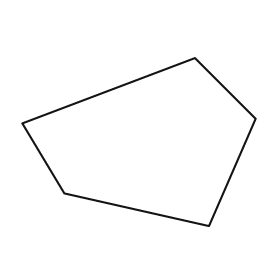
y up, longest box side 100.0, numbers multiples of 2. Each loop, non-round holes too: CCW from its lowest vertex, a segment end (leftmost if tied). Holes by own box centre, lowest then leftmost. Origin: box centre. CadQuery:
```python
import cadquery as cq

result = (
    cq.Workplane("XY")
    .moveTo(30.0, -36.0)
    .lineTo(50.0, 10.0)
    .lineTo(24.0, 36.0)
    .lineTo(-50.0, 8.0)
    .lineTo(-32.0, -22.0)
    .close()
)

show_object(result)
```